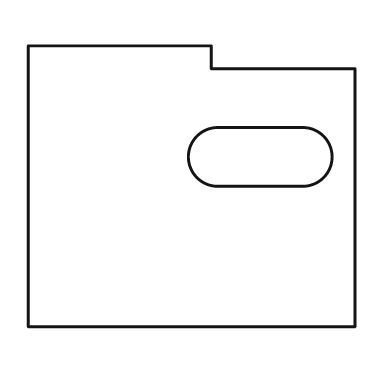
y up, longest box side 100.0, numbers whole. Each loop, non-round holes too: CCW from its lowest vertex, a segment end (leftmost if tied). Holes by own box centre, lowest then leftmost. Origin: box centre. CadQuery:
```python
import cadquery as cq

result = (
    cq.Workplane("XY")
    .moveTo(-50.0, -43.0)
    .lineTo(50.0, -43.0)
    .lineTo(50.0, 36.0)
    .lineTo(6.0, 36.0)
    .lineTo(6.0, 43.0)
    .lineTo(-50.0, 43.0)
    .close()
    .moveTo(8.0, 0.0)
    .lineTo(34.0, 0.0)
    .threePointArc((43.0, 9.0), (34.0, 18.0))
    .lineTo(8.0, 18.0)
    .threePointArc((-1.0, 9.0), (8.0, 0.0))
    .close()
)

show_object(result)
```